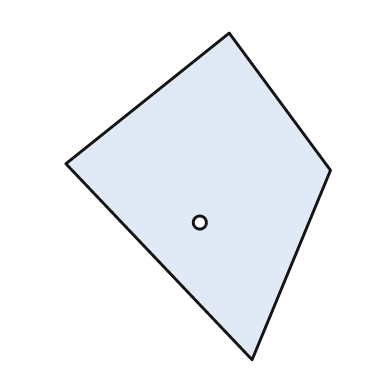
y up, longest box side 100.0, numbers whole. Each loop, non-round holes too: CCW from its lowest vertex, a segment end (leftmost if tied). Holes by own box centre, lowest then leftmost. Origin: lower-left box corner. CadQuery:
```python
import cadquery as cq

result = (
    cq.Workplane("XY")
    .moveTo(57.0, 0.0)
    .lineTo(81.0, 58.0)
    .lineTo(50.0, 100.0)
    .lineTo(0.0, 60.0)
    .close()
    .moveTo(41.0, 42.0)
    .circle(2.0)
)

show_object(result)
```